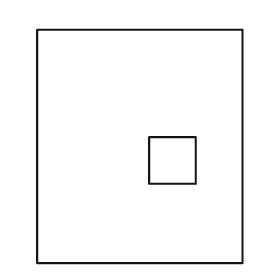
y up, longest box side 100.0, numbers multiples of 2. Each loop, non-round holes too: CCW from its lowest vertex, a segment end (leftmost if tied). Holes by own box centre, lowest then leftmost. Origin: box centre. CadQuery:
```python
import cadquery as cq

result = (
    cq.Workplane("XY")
    .moveTo(-44.0, -50.0)
    .lineTo(44.0, -50.0)
    .lineTo(44.0, 50.0)
    .lineTo(-44.0, 50.0)
    .close()
    .moveTo(4.0, -16.0)
    .lineTo(24.0, -16.0)
    .lineTo(24.0, 4.0)
    .lineTo(4.0, 4.0)
    .close()
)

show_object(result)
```